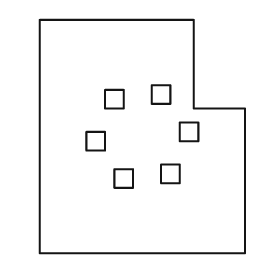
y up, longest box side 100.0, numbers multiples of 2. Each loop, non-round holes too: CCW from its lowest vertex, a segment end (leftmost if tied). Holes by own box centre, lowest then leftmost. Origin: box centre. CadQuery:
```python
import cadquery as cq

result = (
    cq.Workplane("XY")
    .moveTo(-44.0, -50.0)
    .lineTo(44.0, -50.0)
    .lineTo(44.0, 12.0)
    .lineTo(22.0, 12.0)
    .lineTo(22.0, 50.0)
    .lineTo(-44.0, 50.0)
    .close()
    .moveTo(-12.0, -22.0)
    .lineTo(-4.0, -22.0)
    .lineTo(-4.0, -14.0)
    .lineTo(-12.0, -14.0)
    .close()
    .moveTo(8.0, -20.0)
    .lineTo(16.0, -20.0)
    .lineTo(16.0, -12.0)
    .lineTo(8.0, -12.0)
    .close()
    .moveTo(-24.0, -6.0)
    .lineTo(-16.0, -6.0)
    .lineTo(-16.0, 2.0)
    .lineTo(-24.0, 2.0)
    .close()
    .moveTo(16.0, -2.0)
    .lineTo(24.0, -2.0)
    .lineTo(24.0, 6.0)
    .lineTo(16.0, 6.0)
    .close()
    .moveTo(-16.0, 12.0)
    .lineTo(-8.0, 12.0)
    .lineTo(-8.0, 20.0)
    .lineTo(-16.0, 20.0)
    .close()
    .moveTo(4.0, 14.0)
    .lineTo(12.0, 14.0)
    .lineTo(12.0, 22.0)
    .lineTo(4.0, 22.0)
    .close()
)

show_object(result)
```